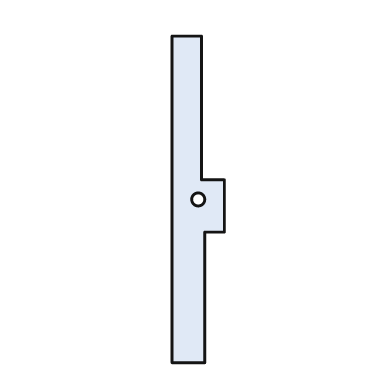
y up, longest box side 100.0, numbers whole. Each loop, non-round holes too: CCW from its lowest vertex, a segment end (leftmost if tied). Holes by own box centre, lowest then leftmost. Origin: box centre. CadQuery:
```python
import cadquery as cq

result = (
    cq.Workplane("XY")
    .moveTo(-8.0, -50.0)
    .lineTo(2.0, -50.0)
    .lineTo(2.0, -10.0)
    .lineTo(8.0, -10.0)
    .lineTo(8.0, 6.0)
    .lineTo(1.0, 6.0)
    .lineTo(1.0, 50.0)
    .lineTo(-8.0, 50.0)
    .close()
    .moveTo(0.0, 0.0)
    .circle(2.0)
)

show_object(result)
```